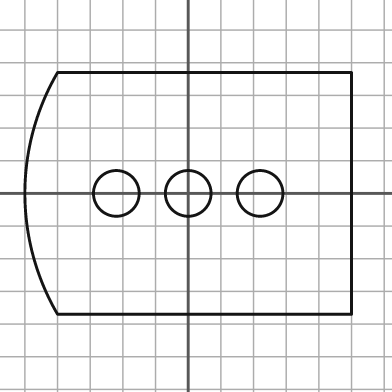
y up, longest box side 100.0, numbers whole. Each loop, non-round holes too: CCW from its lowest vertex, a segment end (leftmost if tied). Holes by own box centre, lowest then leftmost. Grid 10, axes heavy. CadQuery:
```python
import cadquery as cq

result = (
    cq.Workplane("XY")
    .moveTo(-40.0, -37.0)
    .lineTo(50.0, -37.0)
    .lineTo(50.0, 37.0)
    .lineTo(-40.0, 37.0)
    .threePointArc((-50.0, 0.0), (-40.0, -37.0))
    .close()
    .moveTo(-22.0, 0.0)
    .circle(7.0)
    .moveTo(0.0, 0.0)
    .circle(7.0)
    .moveTo(22.0, 0.0)
    .circle(7.0)
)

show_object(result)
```